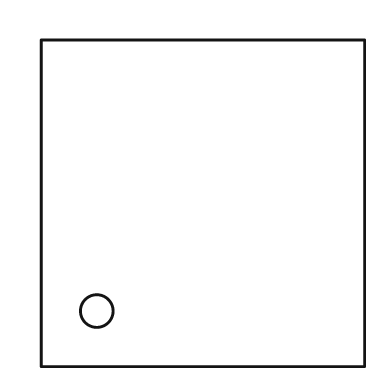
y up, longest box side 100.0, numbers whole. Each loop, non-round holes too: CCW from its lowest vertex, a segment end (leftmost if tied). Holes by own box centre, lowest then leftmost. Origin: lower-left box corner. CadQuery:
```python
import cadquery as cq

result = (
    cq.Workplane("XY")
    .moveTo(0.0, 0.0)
    .lineTo(99.0, 0.0)
    .lineTo(99.0, 100.0)
    .lineTo(0.0, 100.0)
    .close()
    .moveTo(17.0, 17.0)
    .circle(5.0)
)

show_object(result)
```